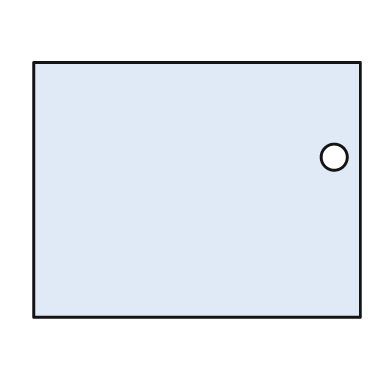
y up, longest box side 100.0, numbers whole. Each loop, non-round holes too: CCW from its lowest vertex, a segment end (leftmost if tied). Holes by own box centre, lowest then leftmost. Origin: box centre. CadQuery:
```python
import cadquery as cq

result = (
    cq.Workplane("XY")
    .moveTo(-50.0, -39.0)
    .lineTo(50.0, -39.0)
    .lineTo(50.0, 39.0)
    .lineTo(-50.0, 39.0)
    .close()
    .moveTo(42.0, 10.0)
    .circle(4.0)
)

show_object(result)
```